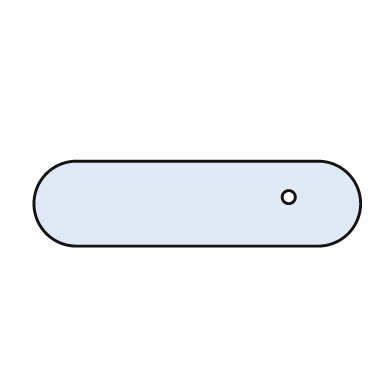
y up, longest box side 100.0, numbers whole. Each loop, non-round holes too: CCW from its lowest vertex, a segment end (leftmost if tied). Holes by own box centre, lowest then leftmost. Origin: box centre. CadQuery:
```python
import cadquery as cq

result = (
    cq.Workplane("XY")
    .moveTo(-37.0, -13.0)
    .lineTo(37.0, -13.0)
    .threePointArc((50.0, 0.0), (37.0, 13.0))
    .lineTo(-37.0, 13.0)
    .threePointArc((-50.0, 0.0), (-37.0, -13.0))
    .close()
    .moveTo(28.0, 2.0)
    .circle(2.0)
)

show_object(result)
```